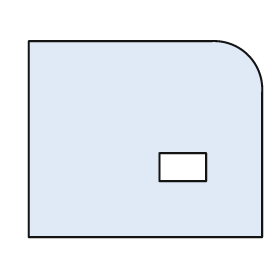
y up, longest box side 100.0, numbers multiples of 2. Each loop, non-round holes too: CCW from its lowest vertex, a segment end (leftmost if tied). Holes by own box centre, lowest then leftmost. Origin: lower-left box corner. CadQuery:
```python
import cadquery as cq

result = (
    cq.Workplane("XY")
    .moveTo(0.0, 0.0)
    .lineTo(100.0, 0.0)
    .lineTo(100.0, 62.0)
    .threePointArc((94.0, 78.0), (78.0, 84.0))
    .lineTo(0.0, 84.0)
    .close()
    .moveTo(56.0, 24.0)
    .lineTo(76.0, 24.0)
    .lineTo(76.0, 36.0)
    .lineTo(56.0, 36.0)
    .close()
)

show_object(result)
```